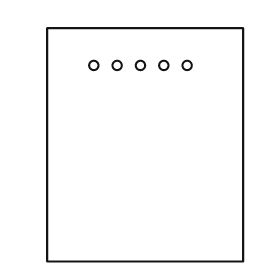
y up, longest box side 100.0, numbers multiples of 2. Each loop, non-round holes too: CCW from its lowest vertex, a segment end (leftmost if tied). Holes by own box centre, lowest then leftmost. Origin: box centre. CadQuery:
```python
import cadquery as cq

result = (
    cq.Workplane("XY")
    .moveTo(-42.0, -50.0)
    .lineTo(42.0, -50.0)
    .lineTo(42.0, 50.0)
    .lineTo(-42.0, 50.0)
    .close()
    .moveTo(-22.0, 34.0)
    .circle(2.0)
    .moveTo(-12.0, 34.0)
    .circle(2.0)
    .moveTo(-2.0, 34.0)
    .circle(2.0)
    .moveTo(8.0, 34.0)
    .circle(2.0)
    .moveTo(18.0, 34.0)
    .circle(2.0)
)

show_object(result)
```